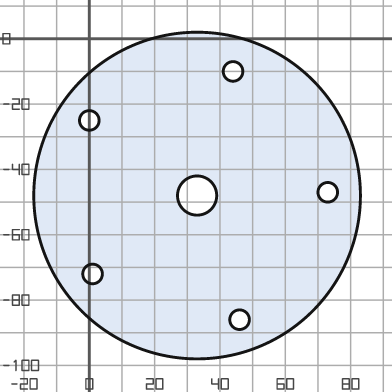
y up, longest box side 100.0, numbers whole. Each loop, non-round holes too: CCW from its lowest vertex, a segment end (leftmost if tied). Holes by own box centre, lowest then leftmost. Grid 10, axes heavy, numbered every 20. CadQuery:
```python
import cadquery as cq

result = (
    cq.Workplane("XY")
    .moveTo(33.0, -48.0)
    .circle(50.0)
    .moveTo(46.0, -86.0)
    .circle(3.0)
    .moveTo(1.0, -72.0)
    .circle(3.0)
    .moveTo(33.0, -48.0)
    .circle(6.0)
    .moveTo(73.0, -47.0)
    .circle(3.0)
    .moveTo(0.0, -25.0)
    .circle(3.0)
    .moveTo(44.0, -10.0)
    .circle(3.0)
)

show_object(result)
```